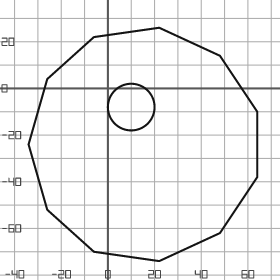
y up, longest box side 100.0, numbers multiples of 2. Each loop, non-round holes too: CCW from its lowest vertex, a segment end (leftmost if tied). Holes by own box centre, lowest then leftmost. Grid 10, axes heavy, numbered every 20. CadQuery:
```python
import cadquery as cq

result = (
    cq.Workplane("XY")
    .moveTo(22.0, -74.0)
    .lineTo(48.0, -62.0)
    .lineTo(64.0, -38.0)
    .lineTo(64.0, -10.0)
    .lineTo(48.0, 14.0)
    .lineTo(22.0, 26.0)
    .lineTo(-6.0, 22.0)
    .lineTo(-26.0, 4.0)
    .lineTo(-34.0, -24.0)
    .lineTo(-26.0, -52.0)
    .lineTo(-6.0, -70.0)
    .close()
    .moveTo(10.0, -8.0)
    .circle(10.0)
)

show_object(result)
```